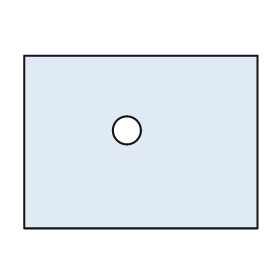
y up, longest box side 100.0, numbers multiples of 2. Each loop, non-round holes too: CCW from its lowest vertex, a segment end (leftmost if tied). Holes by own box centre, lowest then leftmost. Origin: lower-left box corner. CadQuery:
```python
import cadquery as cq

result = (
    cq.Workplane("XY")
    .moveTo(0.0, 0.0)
    .lineTo(100.0, 0.0)
    .lineTo(100.0, 74.0)
    .lineTo(0.0, 74.0)
    .close()
    .moveTo(44.0, 42.0)
    .circle(6.0)
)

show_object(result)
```